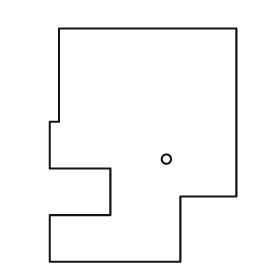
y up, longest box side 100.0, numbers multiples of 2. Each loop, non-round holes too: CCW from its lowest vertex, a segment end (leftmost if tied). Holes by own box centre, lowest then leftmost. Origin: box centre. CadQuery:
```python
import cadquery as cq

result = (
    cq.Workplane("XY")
    .moveTo(-40.0, -50.0)
    .lineTo(16.0, -50.0)
    .lineTo(16.0, -22.0)
    .lineTo(40.0, -22.0)
    .lineTo(40.0, 50.0)
    .lineTo(-36.0, 50.0)
    .lineTo(-36.0, 10.0)
    .lineTo(-40.0, 10.0)
    .lineTo(-40.0, -10.0)
    .lineTo(-14.0, -10.0)
    .lineTo(-14.0, -30.0)
    .lineTo(-40.0, -30.0)
    .close()
    .moveTo(10.0, -6.0)
    .circle(2.0)
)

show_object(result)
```